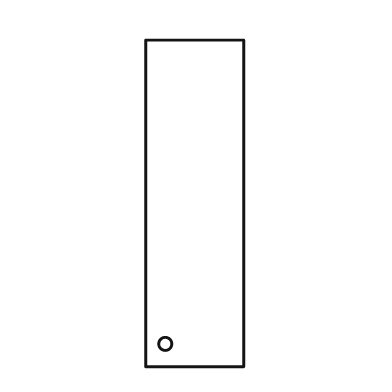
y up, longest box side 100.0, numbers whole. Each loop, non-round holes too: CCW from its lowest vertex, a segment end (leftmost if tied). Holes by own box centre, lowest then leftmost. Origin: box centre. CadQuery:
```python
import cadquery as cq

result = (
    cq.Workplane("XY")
    .moveTo(-15.0, -50.0)
    .lineTo(15.0, -50.0)
    .lineTo(15.0, 50.0)
    .lineTo(-15.0, 50.0)
    .close()
    .moveTo(-9.0, -43.0)
    .circle(2.0)
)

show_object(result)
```